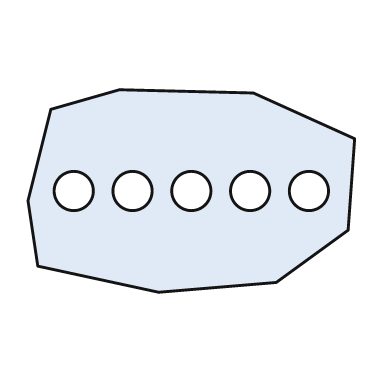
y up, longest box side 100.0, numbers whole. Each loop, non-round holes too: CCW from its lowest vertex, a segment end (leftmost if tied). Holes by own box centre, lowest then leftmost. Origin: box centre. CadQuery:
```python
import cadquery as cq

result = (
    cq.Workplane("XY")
    .moveTo(-10.0, -31.0)
    .lineTo(26.0, -28.0)
    .lineTo(48.0, -12.0)
    .lineTo(50.0, 16.0)
    .lineTo(19.0, 30.0)
    .lineTo(-22.0, 31.0)
    .lineTo(-43.0, 25.0)
    .lineTo(-50.0, -3.0)
    .lineTo(-47.0, -23.0)
    .close()
    .moveTo(-36.0, 0.0)
    .circle(6.0)
    .moveTo(-18.0, 0.0)
    .circle(6.0)
    .moveTo(0.0, 0.0)
    .circle(6.0)
    .moveTo(18.0, 0.0)
    .circle(6.0)
    .moveTo(36.0, 0.0)
    .circle(6.0)
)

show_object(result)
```